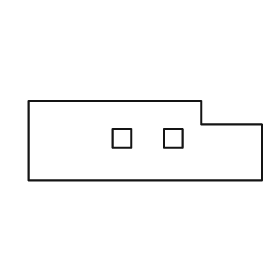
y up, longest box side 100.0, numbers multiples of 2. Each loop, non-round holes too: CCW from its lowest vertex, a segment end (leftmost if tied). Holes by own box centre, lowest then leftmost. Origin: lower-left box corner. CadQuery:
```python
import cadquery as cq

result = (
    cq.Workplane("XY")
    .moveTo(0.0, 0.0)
    .lineTo(100.0, 0.0)
    .lineTo(100.0, 24.0)
    .lineTo(74.0, 24.0)
    .lineTo(74.0, 34.0)
    .lineTo(0.0, 34.0)
    .close()
    .moveTo(36.0, 14.0)
    .lineTo(44.0, 14.0)
    .lineTo(44.0, 22.0)
    .lineTo(36.0, 22.0)
    .close()
    .moveTo(58.0, 14.0)
    .lineTo(66.0, 14.0)
    .lineTo(66.0, 22.0)
    .lineTo(58.0, 22.0)
    .close()
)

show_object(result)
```